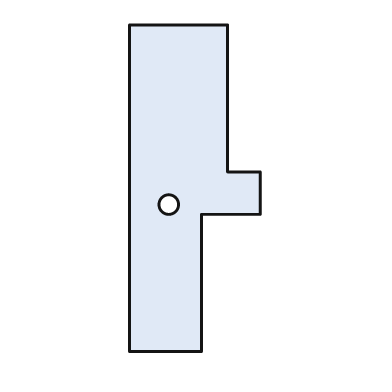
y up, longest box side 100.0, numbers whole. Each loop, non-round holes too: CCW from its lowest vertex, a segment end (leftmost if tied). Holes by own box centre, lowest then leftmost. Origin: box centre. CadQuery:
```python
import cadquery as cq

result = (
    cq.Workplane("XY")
    .moveTo(-20.0, -50.0)
    .lineTo(2.0, -50.0)
    .lineTo(2.0, -8.0)
    .lineTo(20.0, -8.0)
    .lineTo(20.0, 5.0)
    .lineTo(10.0, 5.0)
    .lineTo(10.0, 50.0)
    .lineTo(-20.0, 50.0)
    .close()
    .moveTo(-8.0, -5.0)
    .circle(3.0)
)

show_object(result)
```